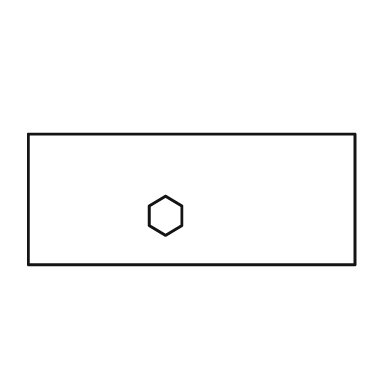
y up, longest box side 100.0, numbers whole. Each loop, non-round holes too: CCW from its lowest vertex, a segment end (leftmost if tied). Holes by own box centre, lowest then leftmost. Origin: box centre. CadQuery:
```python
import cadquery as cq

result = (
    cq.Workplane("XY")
    .moveTo(-50.0, -20.0)
    .lineTo(50.0, -20.0)
    .lineTo(50.0, 20.0)
    .lineTo(-50.0, 20.0)
    .close()
    .moveTo(-8.0, -11.0)
    .lineTo(-3.0, -8.0)
    .lineTo(-3.0, -2.0)
    .lineTo(-8.0, 1.0)
    .lineTo(-13.0, -2.0)
    .lineTo(-13.0, -8.0)
    .close()
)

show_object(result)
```